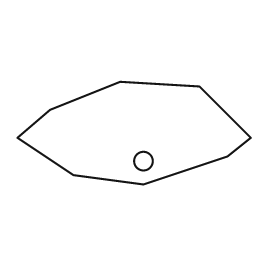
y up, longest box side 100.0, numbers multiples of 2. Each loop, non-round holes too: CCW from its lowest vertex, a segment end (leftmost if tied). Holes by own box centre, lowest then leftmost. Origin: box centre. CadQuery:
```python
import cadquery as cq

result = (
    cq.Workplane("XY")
    .moveTo(4.0, -22.0)
    .lineTo(40.0, -10.0)
    .lineTo(50.0, -2.0)
    .lineTo(28.0, 20.0)
    .lineTo(-6.0, 22.0)
    .lineTo(-36.0, 10.0)
    .lineTo(-50.0, -2.0)
    .lineTo(-26.0, -18.0)
    .close()
    .moveTo(4.0, -12.0)
    .circle(4.0)
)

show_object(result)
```